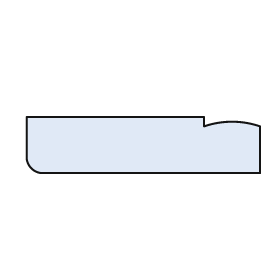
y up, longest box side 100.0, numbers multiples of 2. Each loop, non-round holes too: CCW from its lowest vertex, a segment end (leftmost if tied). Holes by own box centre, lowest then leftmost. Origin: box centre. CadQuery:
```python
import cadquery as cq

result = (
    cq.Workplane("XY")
    .moveTo(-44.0, -12.0)
    .lineTo(50.0, -12.0)
    .lineTo(50.0, 8.0)
    .threePointArc((38.0, 10.0), (26.0, 8.0))
    .lineTo(26.0, 12.0)
    .lineTo(-50.0, 12.0)
    .lineTo(-50.0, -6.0)
    .threePointArc((-48.0, -10.0), (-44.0, -12.0))
    .close()
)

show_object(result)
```